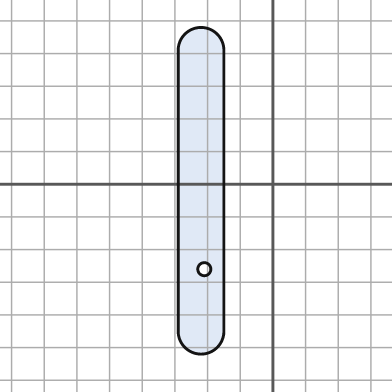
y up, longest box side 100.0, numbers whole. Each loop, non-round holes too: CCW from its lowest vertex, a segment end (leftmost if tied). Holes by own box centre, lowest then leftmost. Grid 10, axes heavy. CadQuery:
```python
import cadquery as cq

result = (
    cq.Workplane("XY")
    .moveTo(-29.0, -45.0)
    .threePointArc((-22.0, -52.0), (-15.0, -45.0))
    .lineTo(-15.0, 41.0)
    .threePointArc((-22.0, 48.0), (-29.0, 41.0))
    .close()
    .moveTo(-21.0, -26.0)
    .circle(2.0)
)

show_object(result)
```